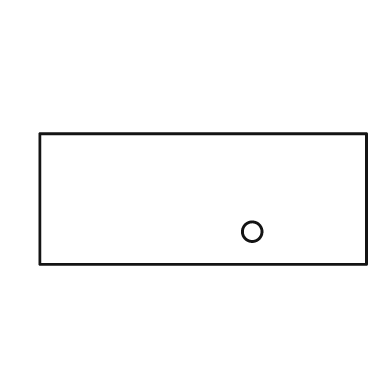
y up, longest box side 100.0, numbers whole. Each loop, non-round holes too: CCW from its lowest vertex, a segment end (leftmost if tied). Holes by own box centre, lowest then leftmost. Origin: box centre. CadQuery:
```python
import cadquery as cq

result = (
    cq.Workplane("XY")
    .moveTo(-50.0, -20.0)
    .lineTo(50.0, -20.0)
    .lineTo(50.0, 20.0)
    .lineTo(-50.0, 20.0)
    .close()
    .moveTo(15.0, -10.0)
    .circle(3.0)
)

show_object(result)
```